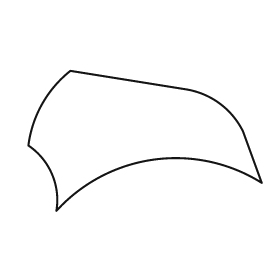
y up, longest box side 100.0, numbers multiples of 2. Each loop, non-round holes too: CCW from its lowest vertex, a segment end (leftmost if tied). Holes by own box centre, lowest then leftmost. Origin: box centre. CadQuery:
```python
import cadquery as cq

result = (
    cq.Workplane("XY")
    .moveTo(-38.0, -30.0)
    .threePointArc((4.0, -8.0), (50.0, -18.0))
    .lineTo(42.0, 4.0)
    .threePointArc((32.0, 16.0), (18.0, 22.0))
    .lineTo(-32.0, 30.0)
    .threePointArc((-44.0, 16.0), (-50.0, -2.0))
    .threePointArc((-40.0, -14.0), (-38.0, -30.0))
    .close()
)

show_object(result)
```